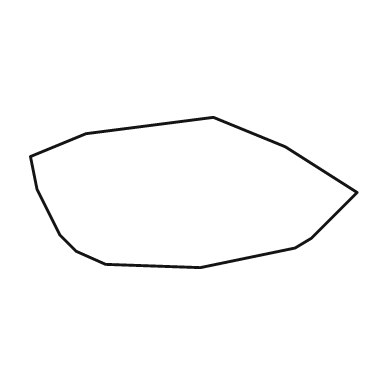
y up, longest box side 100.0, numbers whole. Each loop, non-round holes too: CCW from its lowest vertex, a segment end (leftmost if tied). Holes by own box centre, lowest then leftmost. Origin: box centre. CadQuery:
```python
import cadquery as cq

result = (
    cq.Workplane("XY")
    .moveTo(2.0, -23.0)
    .lineTo(31.0, -17.0)
    .lineTo(36.0, -14.0)
    .lineTo(50.0, 0.0)
    .lineTo(28.0, 14.0)
    .lineTo(6.0, 23.0)
    .lineTo(-33.0, 18.0)
    .lineTo(-50.0, 11.0)
    .lineTo(-48.0, 1.0)
    .lineTo(-41.0, -13.0)
    .lineTo(-36.0, -18.0)
    .lineTo(-27.0, -22.0)
    .close()
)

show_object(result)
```